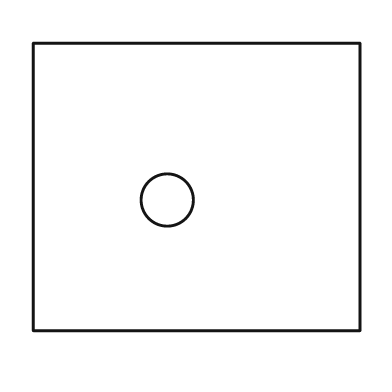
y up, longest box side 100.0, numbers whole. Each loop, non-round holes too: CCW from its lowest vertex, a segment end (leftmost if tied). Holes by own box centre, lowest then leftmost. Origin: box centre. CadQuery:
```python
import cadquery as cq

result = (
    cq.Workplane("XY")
    .moveTo(-50.0, -44.0)
    .lineTo(50.0, -44.0)
    .lineTo(50.0, 44.0)
    .lineTo(-50.0, 44.0)
    .close()
    .moveTo(-9.0, -4.0)
    .circle(8.0)
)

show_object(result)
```